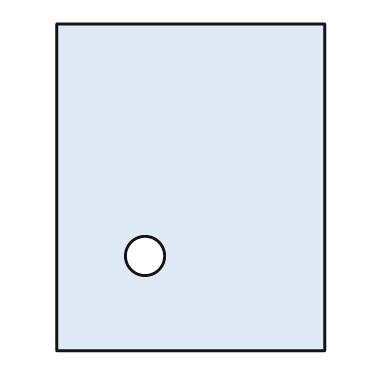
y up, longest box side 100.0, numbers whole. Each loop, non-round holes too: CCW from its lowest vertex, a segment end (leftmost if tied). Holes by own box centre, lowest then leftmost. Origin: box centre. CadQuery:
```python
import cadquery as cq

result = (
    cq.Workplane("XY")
    .moveTo(-41.0, -50.0)
    .lineTo(41.0, -50.0)
    .lineTo(41.0, 50.0)
    .lineTo(-41.0, 50.0)
    .close()
    .moveTo(-14.0, -21.0)
    .circle(6.0)
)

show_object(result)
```